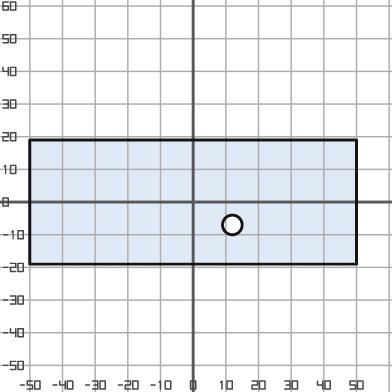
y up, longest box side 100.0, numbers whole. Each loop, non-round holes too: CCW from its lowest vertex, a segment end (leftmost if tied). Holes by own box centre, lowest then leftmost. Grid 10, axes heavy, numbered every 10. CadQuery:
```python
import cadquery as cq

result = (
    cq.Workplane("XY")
    .moveTo(-50.0, -19.0)
    .lineTo(50.0, -19.0)
    .lineTo(50.0, 19.0)
    .lineTo(-50.0, 19.0)
    .close()
    .moveTo(12.0, -7.0)
    .circle(3.0)
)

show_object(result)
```